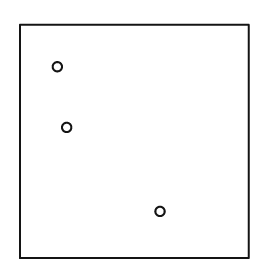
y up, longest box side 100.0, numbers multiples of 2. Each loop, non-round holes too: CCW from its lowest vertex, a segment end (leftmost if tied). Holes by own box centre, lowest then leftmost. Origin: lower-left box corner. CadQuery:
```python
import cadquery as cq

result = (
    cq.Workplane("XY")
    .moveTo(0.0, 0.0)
    .lineTo(98.0, 0.0)
    .lineTo(98.0, 100.0)
    .lineTo(0.0, 100.0)
    .close()
    .moveTo(60.0, 20.0)
    .circle(2.0)
    .moveTo(20.0, 56.0)
    .circle(2.0)
    .moveTo(16.0, 82.0)
    .circle(2.0)
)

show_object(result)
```